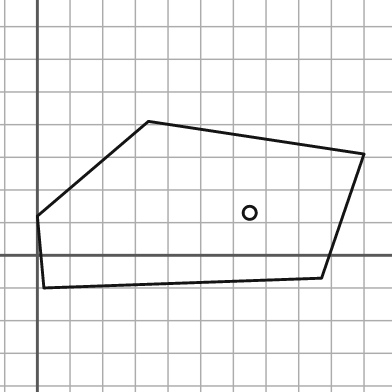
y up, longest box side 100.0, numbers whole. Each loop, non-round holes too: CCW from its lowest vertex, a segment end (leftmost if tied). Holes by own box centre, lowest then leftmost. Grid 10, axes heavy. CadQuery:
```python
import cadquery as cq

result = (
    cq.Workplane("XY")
    .moveTo(2.0, -10.0)
    .lineTo(87.0, -7.0)
    .lineTo(100.0, 31.0)
    .lineTo(34.0, 41.0)
    .lineTo(0.0, 12.0)
    .close()
    .moveTo(65.0, 13.0)
    .circle(2.0)
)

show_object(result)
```